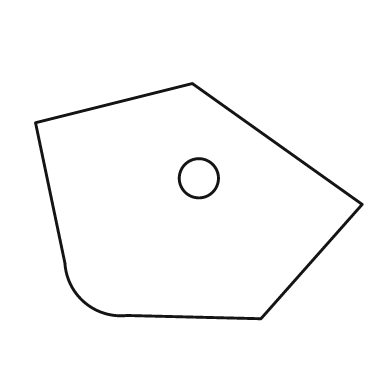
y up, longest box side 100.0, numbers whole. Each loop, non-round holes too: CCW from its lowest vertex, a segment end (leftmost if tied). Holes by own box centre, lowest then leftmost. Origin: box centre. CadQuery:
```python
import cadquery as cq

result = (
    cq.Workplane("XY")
    .moveTo(19.0, -36.0)
    .lineTo(50.0, -1.0)
    .lineTo(-2.0, 36.0)
    .lineTo(-50.0, 24.0)
    .lineTo(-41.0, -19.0)
    .threePointArc((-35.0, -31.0), (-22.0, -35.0))
    .close()
    .moveTo(0.0, 7.0)
    .circle(6.0)
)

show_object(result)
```